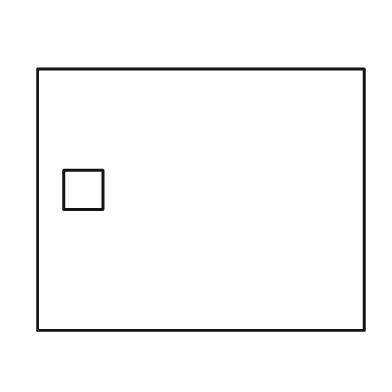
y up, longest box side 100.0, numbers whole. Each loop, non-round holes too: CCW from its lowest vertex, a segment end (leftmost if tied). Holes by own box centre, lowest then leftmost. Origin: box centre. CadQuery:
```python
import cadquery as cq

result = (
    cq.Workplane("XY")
    .moveTo(-50.0, -40.0)
    .lineTo(50.0, -40.0)
    .lineTo(50.0, 40.0)
    .lineTo(-50.0, 40.0)
    .close()
    .moveTo(-42.0, -3.0)
    .lineTo(-30.0, -3.0)
    .lineTo(-30.0, 9.0)
    .lineTo(-42.0, 9.0)
    .close()
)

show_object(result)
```